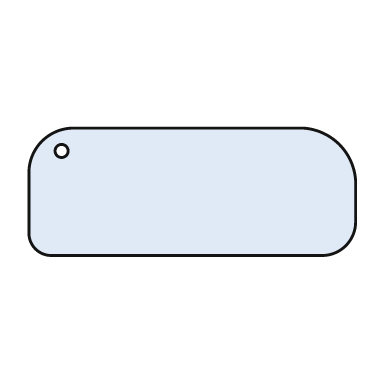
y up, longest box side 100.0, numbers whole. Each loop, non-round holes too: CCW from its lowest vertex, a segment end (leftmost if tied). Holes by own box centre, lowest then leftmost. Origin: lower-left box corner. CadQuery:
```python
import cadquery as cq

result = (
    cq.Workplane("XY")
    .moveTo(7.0, 0.0)
    .lineTo(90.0, 0.0)
    .threePointArc((97.0, 3.0), (100.0, 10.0))
    .lineTo(100.0, 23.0)
    .threePointArc((95.0, 34.0), (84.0, 39.0))
    .lineTo(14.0, 39.0)
    .threePointArc((4.0, 35.0), (0.0, 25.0))
    .lineTo(0.0, 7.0)
    .threePointArc((2.0, 2.0), (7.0, 0.0))
    .close()
    .moveTo(10.0, 32.0)
    .circle(2.0)
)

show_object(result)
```